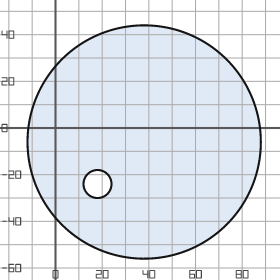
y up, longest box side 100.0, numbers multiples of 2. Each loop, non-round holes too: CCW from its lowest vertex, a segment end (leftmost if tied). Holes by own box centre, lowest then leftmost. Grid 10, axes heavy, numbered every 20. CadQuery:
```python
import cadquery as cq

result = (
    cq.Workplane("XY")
    .moveTo(38.0, -6.0)
    .circle(50.0)
    .moveTo(18.0, -24.0)
    .circle(6.0)
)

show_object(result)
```